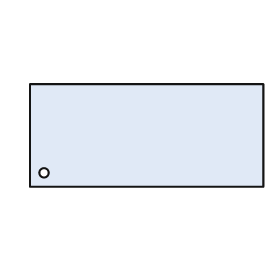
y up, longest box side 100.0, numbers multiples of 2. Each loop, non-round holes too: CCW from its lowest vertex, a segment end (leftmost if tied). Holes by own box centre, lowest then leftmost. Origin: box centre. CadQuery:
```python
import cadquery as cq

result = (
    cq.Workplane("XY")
    .moveTo(-50.0, -22.0)
    .lineTo(50.0, -22.0)
    .lineTo(50.0, 22.0)
    .lineTo(-50.0, 22.0)
    .close()
    .moveTo(-44.0, -16.0)
    .circle(2.0)
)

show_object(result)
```